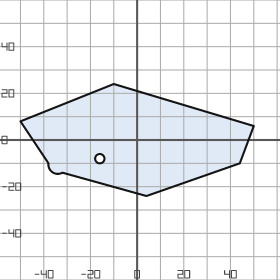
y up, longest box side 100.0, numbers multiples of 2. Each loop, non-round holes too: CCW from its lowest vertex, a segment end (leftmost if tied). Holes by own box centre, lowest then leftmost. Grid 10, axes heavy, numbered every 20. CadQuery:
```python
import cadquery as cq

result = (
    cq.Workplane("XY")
    .moveTo(4.0, -24.0)
    .lineTo(44.0, -10.0)
    .lineTo(50.0, 6.0)
    .lineTo(-10.0, 24.0)
    .lineTo(-50.0, 8.0)
    .lineTo(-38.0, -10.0)
    .threePointArc((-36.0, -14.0), (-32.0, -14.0))
    .close()
    .moveTo(-16.0, -8.0)
    .circle(2.0)
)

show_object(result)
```